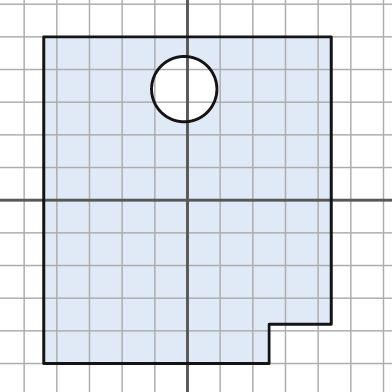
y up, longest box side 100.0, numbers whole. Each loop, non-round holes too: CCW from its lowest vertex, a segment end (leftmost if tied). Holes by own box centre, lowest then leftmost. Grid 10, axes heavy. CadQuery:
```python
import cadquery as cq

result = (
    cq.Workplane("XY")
    .moveTo(-44.0, -50.0)
    .lineTo(25.0, -50.0)
    .lineTo(25.0, -38.0)
    .lineTo(44.0, -38.0)
    .lineTo(44.0, 50.0)
    .lineTo(-44.0, 50.0)
    .close()
    .moveTo(-1.0, 34.0)
    .circle(10.0)
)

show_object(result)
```